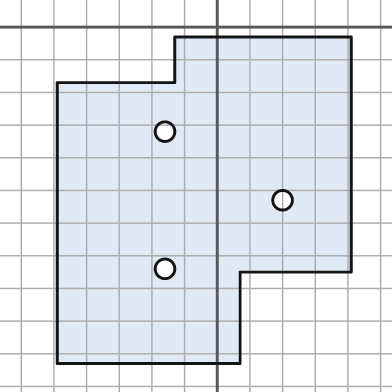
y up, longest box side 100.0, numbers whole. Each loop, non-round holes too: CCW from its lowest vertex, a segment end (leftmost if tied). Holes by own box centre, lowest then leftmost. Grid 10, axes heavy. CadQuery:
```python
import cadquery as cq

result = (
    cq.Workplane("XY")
    .moveTo(-49.0, -103.0)
    .lineTo(7.0, -103.0)
    .lineTo(7.0, -75.0)
    .lineTo(41.0, -75.0)
    .lineTo(41.0, -3.0)
    .lineTo(-13.0, -3.0)
    .lineTo(-13.0, -17.0)
    .lineTo(-49.0, -17.0)
    .close()
    .moveTo(-16.0, -74.0)
    .circle(3.0)
    .moveTo(20.0, -53.0)
    .circle(3.0)
    .moveTo(-16.0, -32.0)
    .circle(3.0)
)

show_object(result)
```